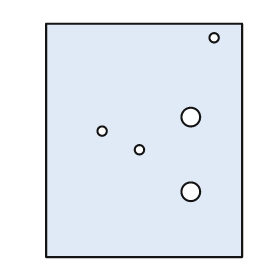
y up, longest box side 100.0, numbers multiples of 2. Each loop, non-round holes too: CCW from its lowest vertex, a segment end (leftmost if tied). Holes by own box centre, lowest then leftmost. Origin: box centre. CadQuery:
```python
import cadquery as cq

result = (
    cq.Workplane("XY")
    .moveTo(-42.0, -50.0)
    .lineTo(42.0, -50.0)
    .lineTo(42.0, 50.0)
    .lineTo(-42.0, 50.0)
    .close()
    .moveTo(20.0, -22.0)
    .circle(4.0)
    .moveTo(-2.0, -4.0)
    .circle(2.0)
    .moveTo(-18.0, 4.0)
    .circle(2.0)
    .moveTo(20.0, 10.0)
    .circle(4.0)
    .moveTo(30.0, 44.0)
    .circle(2.0)
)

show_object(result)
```